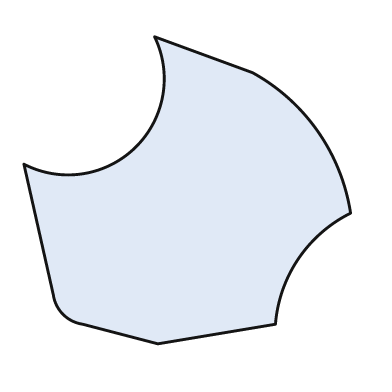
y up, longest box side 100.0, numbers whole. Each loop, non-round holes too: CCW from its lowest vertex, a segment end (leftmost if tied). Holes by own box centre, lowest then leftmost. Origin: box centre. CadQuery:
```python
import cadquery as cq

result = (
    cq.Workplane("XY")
    .moveTo(-9.0, -47.0)
    .lineTo(27.0, -41.0)
    .threePointArc((34.0, -21.0), (50.0, -7.0))
    .threePointArc((40.0, 18.0), (20.0, 36.0))
    .lineTo(-10.0, 47.0)
    .threePointArc((-16.0, 13.0), (-50.0, 8.0))
    .lineTo(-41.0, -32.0)
    .threePointArc((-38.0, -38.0), (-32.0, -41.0))
    .close()
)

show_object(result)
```